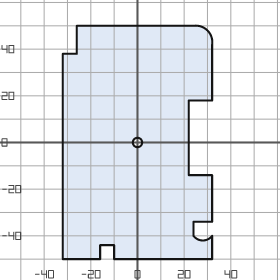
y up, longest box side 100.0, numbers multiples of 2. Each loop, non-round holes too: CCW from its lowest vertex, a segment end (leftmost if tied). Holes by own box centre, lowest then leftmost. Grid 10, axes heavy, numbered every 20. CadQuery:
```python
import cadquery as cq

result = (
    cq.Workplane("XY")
    .moveTo(-32.0, -50.0)
    .lineTo(-16.0, -50.0)
    .lineTo(-16.0, -44.0)
    .lineTo(-10.0, -44.0)
    .lineTo(-10.0, -50.0)
    .lineTo(32.0, -50.0)
    .lineTo(32.0, -40.0)
    .threePointArc((28.0, -42.0), (24.0, -40.0))
    .lineTo(24.0, -34.0)
    .lineTo(32.0, -34.0)
    .lineTo(32.0, -14.0)
    .lineTo(22.0, -14.0)
    .lineTo(22.0, 18.0)
    .lineTo(32.0, 18.0)
    .lineTo(32.0, 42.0)
    .threePointArc((30.0, 48.0), (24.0, 50.0))
    .lineTo(-26.0, 50.0)
    .lineTo(-26.0, 38.0)
    .lineTo(-32.0, 38.0)
    .close()
    .moveTo(0.0, 0.0)
    .circle(2.0)
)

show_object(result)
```